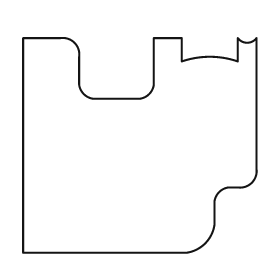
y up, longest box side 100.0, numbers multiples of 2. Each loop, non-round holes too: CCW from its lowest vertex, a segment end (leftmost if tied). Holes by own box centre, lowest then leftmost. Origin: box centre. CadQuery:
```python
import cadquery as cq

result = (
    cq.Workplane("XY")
    .moveTo(-50.0, -46.0)
    .lineTo(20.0, -46.0)
    .threePointArc((28.0, -42.0), (32.0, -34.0))
    .lineTo(32.0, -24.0)
    .threePointArc((34.0, -20.0), (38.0, -18.0))
    .lineTo(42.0, -18.0)
    .threePointArc((48.0, -16.0), (50.0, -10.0))
    .lineTo(50.0, 46.0)
    .threePointArc((46.0, 44.0), (42.0, 46.0))
    .lineTo(42.0, 36.0)
    .threePointArc((30.0, 38.0), (18.0, 36.0))
    .lineTo(18.0, 46.0)
    .lineTo(6.0, 46.0)
    .lineTo(6.0, 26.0)
    .threePointArc((4.0, 22.0), (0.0, 20.0))
    .lineTo(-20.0, 20.0)
    .threePointArc((-24.0, 22.0), (-26.0, 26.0))
    .lineTo(-26.0, 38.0)
    .threePointArc((-28.0, 44.0), (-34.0, 46.0))
    .lineTo(-50.0, 46.0)
    .close()
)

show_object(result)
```